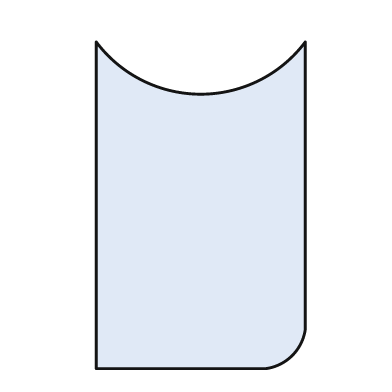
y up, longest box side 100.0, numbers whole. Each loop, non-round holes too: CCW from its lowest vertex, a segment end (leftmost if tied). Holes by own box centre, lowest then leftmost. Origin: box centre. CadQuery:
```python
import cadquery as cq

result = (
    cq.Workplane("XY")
    .moveTo(-32.0, -50.0)
    .lineTo(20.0, -50.0)
    .threePointArc((28.0, -46.0), (32.0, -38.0))
    .lineTo(32.0, 50.0)
    .threePointArc((0.0, 34.0), (-32.0, 50.0))
    .close()
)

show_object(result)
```